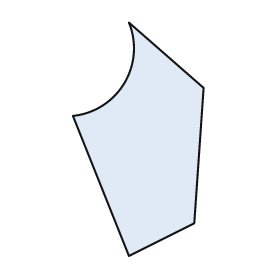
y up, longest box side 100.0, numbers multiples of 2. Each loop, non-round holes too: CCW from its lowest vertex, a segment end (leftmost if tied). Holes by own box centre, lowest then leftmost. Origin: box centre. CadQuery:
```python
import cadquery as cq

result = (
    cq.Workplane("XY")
    .moveTo(-4.0, -50.0)
    .lineTo(24.0, -36.0)
    .lineTo(28.0, 22.0)
    .lineTo(-4.0, 50.0)
    .threePointArc((-6.0, 24.0), (-28.0, 10.0))
    .close()
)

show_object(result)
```